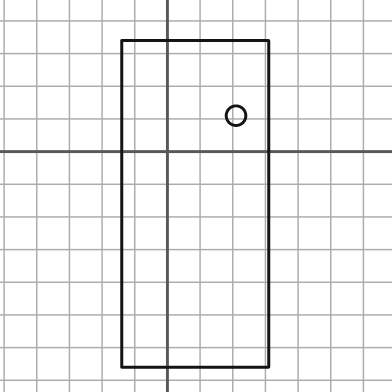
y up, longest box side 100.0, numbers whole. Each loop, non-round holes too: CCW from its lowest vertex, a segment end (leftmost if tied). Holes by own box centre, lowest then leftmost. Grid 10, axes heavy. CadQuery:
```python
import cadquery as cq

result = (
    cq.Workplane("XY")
    .moveTo(-14.0, -66.0)
    .lineTo(31.0, -66.0)
    .lineTo(31.0, 34.0)
    .lineTo(-14.0, 34.0)
    .close()
    .moveTo(21.0, 11.0)
    .circle(3.0)
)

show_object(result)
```